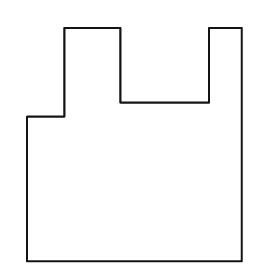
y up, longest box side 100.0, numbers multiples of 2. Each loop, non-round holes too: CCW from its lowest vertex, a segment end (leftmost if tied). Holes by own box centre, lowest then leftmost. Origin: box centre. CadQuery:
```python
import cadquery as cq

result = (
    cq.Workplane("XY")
    .moveTo(-46.0, -50.0)
    .lineTo(46.0, -50.0)
    .lineTo(46.0, 50.0)
    .lineTo(32.0, 50.0)
    .lineTo(32.0, 18.0)
    .lineTo(-6.0, 18.0)
    .lineTo(-6.0, 50.0)
    .lineTo(-30.0, 50.0)
    .lineTo(-30.0, 12.0)
    .lineTo(-46.0, 12.0)
    .close()
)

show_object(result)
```